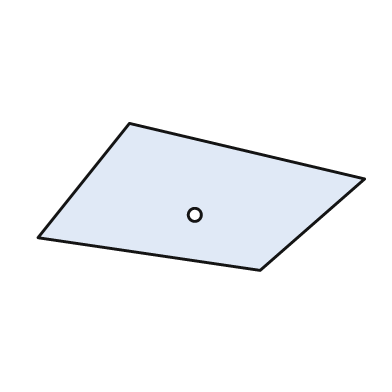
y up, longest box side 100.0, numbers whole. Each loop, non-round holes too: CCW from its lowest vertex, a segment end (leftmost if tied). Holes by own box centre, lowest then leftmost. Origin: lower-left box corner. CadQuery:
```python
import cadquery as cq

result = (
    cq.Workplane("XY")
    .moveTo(68.0, 0.0)
    .lineTo(100.0, 28.0)
    .lineTo(28.0, 45.0)
    .lineTo(0.0, 10.0)
    .close()
    .moveTo(48.0, 17.0)
    .circle(2.0)
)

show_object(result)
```